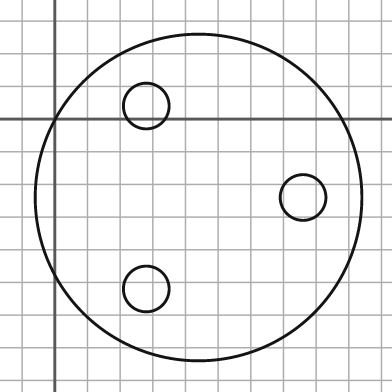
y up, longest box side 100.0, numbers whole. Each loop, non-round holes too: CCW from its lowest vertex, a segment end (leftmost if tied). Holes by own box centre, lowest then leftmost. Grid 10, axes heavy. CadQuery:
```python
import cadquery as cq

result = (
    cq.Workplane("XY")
    .moveTo(44.0, -24.0)
    .circle(50.0)
    .moveTo(28.0, -52.0)
    .circle(7.0)
    .moveTo(76.0, -24.0)
    .circle(7.0)
    .moveTo(28.0, 4.0)
    .circle(7.0)
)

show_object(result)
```